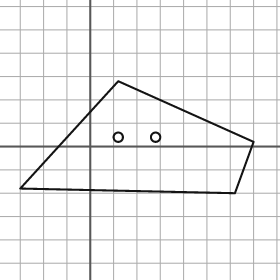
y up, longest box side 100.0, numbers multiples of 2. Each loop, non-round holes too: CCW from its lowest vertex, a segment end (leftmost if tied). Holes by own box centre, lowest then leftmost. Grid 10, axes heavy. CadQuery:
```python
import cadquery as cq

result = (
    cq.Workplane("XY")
    .moveTo(62.0, -20.0)
    .lineTo(70.0, 2.0)
    .lineTo(12.0, 28.0)
    .lineTo(-30.0, -18.0)
    .close()
    .moveTo(12.0, 4.0)
    .circle(2.0)
    .moveTo(28.0, 4.0)
    .circle(2.0)
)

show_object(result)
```